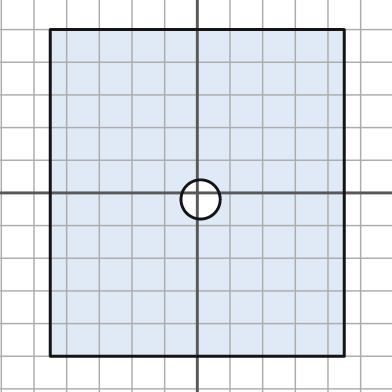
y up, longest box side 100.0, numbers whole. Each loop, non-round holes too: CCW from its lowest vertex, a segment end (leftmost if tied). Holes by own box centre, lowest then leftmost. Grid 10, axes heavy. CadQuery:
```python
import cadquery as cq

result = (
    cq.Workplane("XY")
    .moveTo(-45.0, -50.0)
    .lineTo(45.0, -50.0)
    .lineTo(45.0, 50.0)
    .lineTo(-45.0, 50.0)
    .close()
    .moveTo(1.0, -2.0)
    .circle(6.0)
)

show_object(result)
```